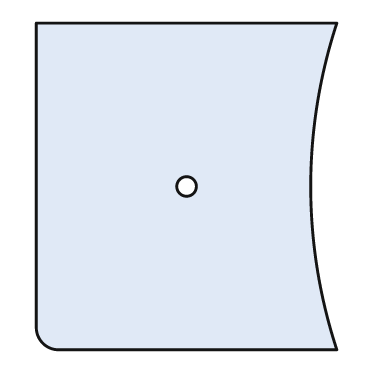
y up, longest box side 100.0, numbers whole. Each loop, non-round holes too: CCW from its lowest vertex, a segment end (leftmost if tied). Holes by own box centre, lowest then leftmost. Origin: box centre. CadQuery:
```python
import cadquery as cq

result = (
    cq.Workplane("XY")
    .moveTo(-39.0, -50.0)
    .lineTo(46.0, -50.0)
    .threePointArc((38.0, 0.0), (46.0, 50.0))
    .lineTo(-46.0, 50.0)
    .lineTo(-46.0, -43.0)
    .threePointArc((-44.0, -48.0), (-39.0, -50.0))
    .close()
    .moveTo(0.0, 0.0)
    .circle(3.0)
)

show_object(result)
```